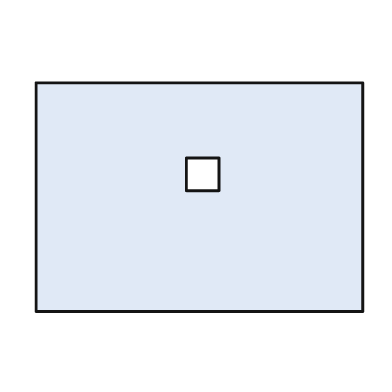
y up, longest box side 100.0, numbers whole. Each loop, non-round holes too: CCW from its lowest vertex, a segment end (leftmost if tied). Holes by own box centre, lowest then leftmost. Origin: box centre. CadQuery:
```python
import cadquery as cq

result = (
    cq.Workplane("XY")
    .moveTo(-50.0, -35.0)
    .lineTo(50.0, -35.0)
    .lineTo(50.0, 35.0)
    .lineTo(-50.0, 35.0)
    .close()
    .moveTo(-4.0, 2.0)
    .lineTo(6.0, 2.0)
    .lineTo(6.0, 12.0)
    .lineTo(-4.0, 12.0)
    .close()
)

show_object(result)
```